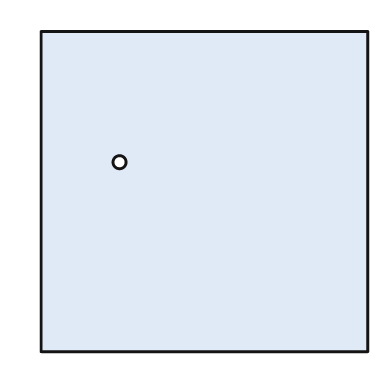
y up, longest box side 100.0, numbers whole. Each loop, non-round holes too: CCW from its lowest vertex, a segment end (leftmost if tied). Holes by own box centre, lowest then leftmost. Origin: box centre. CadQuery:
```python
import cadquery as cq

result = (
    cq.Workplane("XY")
    .moveTo(-50.0, -49.0)
    .lineTo(50.0, -49.0)
    .lineTo(50.0, 49.0)
    .lineTo(-50.0, 49.0)
    .close()
    .moveTo(-26.0, 9.0)
    .circle(2.0)
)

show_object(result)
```